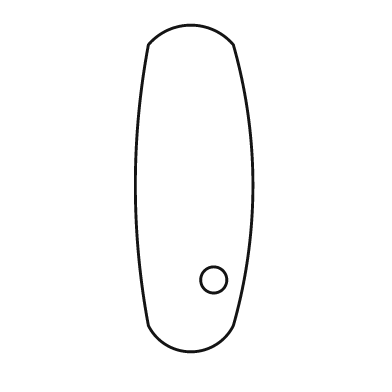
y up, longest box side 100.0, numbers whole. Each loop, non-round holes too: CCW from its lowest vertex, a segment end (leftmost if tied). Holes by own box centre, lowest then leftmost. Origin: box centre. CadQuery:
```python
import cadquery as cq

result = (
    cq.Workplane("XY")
    .moveTo(-14.0, -42.0)
    .threePointArc((-1.0, -50.0), (12.0, -42.0))
    .threePointArc((18.0, 1.0), (12.0, 44.0))
    .threePointArc((-1.0, 50.0), (-14.0, 44.0))
    .threePointArc((-18.0, 1.0), (-14.0, -42.0))
    .close()
    .moveTo(6.0, -28.0)
    .circle(4.0)
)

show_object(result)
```